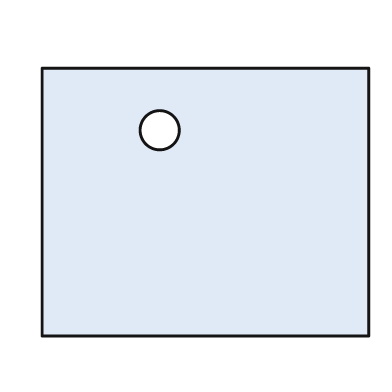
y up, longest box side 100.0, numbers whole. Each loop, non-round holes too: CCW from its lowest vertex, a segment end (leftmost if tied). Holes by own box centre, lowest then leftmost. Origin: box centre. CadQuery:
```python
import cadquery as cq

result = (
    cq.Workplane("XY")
    .moveTo(-50.0, -41.0)
    .lineTo(50.0, -41.0)
    .lineTo(50.0, 41.0)
    .lineTo(-50.0, 41.0)
    .close()
    .moveTo(-14.0, 22.0)
    .circle(6.0)
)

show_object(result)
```